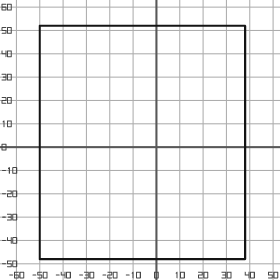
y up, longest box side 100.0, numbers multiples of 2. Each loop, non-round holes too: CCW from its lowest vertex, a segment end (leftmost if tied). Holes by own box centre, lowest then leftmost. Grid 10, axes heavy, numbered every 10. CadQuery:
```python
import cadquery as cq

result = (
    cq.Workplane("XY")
    .moveTo(-50.0, -48.0)
    .lineTo(38.0, -48.0)
    .lineTo(38.0, 52.0)
    .lineTo(-50.0, 52.0)
    .close()
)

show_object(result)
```